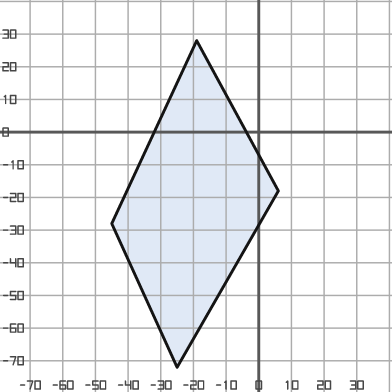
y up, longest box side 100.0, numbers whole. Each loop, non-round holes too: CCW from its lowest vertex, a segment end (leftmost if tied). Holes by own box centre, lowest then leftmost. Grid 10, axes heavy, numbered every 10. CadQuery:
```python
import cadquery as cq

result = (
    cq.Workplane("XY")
    .moveTo(-25.0, -72.0)
    .lineTo(6.0, -18.0)
    .lineTo(-19.0, 28.0)
    .lineTo(-45.0, -28.0)
    .close()
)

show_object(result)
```